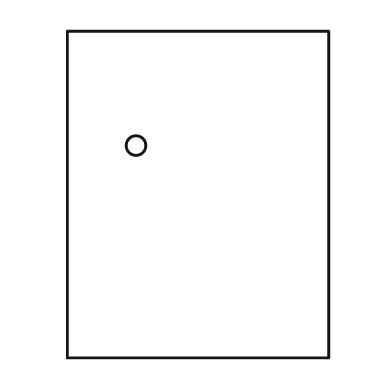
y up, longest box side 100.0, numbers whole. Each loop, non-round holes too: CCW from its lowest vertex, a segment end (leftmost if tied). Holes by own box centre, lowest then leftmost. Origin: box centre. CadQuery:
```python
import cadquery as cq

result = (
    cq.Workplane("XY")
    .moveTo(-40.0, -50.0)
    .lineTo(40.0, -50.0)
    .lineTo(40.0, 50.0)
    .lineTo(-40.0, 50.0)
    .close()
    .moveTo(-19.0, 15.0)
    .circle(3.0)
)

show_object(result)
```